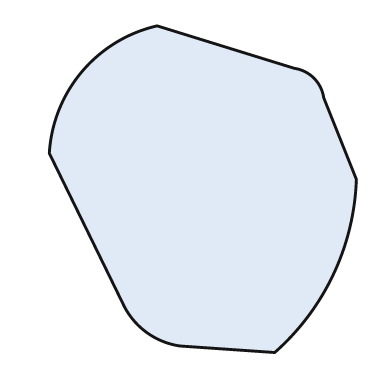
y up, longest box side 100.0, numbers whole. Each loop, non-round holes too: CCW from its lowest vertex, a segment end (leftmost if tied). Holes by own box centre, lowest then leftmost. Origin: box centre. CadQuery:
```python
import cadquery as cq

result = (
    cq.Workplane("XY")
    .moveTo(22.0, -50.0)
    .threePointArc((40.0, -26.0), (47.0, 3.0))
    .lineTo(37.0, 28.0)
    .threePointArc((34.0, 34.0), (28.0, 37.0))
    .lineTo(-14.0, 50.0)
    .threePointArc((-37.0, 36.0), (-47.0, 11.0))
    .lineTo(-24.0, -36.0)
    .threePointArc((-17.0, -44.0), (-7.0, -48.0))
    .close()
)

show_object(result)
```